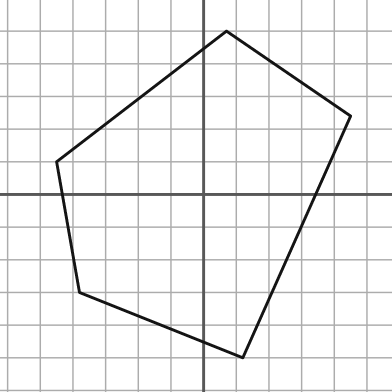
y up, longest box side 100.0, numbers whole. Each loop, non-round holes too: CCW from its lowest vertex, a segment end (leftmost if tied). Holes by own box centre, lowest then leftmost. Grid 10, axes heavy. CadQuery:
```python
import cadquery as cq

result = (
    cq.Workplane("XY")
    .moveTo(12.0, -50.0)
    .lineTo(45.0, 24.0)
    .lineTo(7.0, 50.0)
    .lineTo(-45.0, 10.0)
    .lineTo(-38.0, -30.0)
    .close()
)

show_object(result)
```